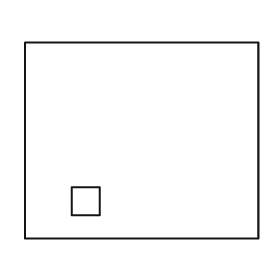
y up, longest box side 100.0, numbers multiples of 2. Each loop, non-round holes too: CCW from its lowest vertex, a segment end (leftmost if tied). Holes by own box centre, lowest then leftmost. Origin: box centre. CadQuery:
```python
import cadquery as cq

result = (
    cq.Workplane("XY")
    .moveTo(-50.0, -42.0)
    .lineTo(50.0, -42.0)
    .lineTo(50.0, 42.0)
    .lineTo(-50.0, 42.0)
    .close()
    .moveTo(-30.0, -32.0)
    .lineTo(-18.0, -32.0)
    .lineTo(-18.0, -20.0)
    .lineTo(-30.0, -20.0)
    .close()
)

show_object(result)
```